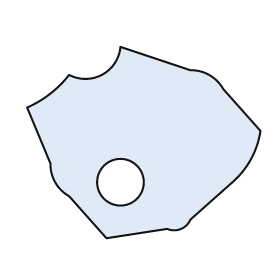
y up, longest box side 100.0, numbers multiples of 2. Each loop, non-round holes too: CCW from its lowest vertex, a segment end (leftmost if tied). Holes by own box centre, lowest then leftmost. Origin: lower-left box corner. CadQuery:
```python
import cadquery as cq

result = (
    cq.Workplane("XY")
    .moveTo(34.0, 0.0)
    .lineTo(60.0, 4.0)
    .threePointArc((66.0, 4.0), (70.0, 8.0))
    .lineTo(88.0, 24.0)
    .threePointArc((96.0, 34.0), (100.0, 46.0))
    .lineTo(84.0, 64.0)
    .threePointArc((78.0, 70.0), (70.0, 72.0))
    .lineTo(40.0, 82.0)
    .threePointArc((32.0, 70.0), (18.0, 70.0))
    .threePointArc((10.0, 62.0), (0.0, 56.0))
    .lineTo(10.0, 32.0)
    .threePointArc((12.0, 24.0), (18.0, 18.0))
    .close()
    .moveTo(40.0, 24.0)
    .circle(10.0)
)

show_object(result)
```